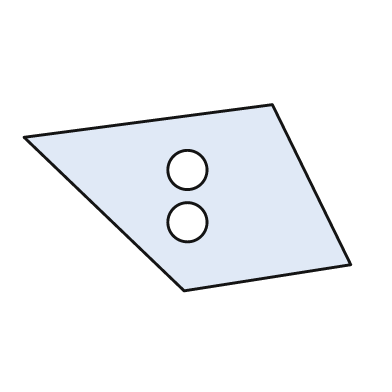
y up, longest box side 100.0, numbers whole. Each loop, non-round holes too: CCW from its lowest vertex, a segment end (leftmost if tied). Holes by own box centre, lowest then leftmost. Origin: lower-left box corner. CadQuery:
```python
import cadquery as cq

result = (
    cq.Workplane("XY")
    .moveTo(49.0, 0.0)
    .lineTo(100.0, 8.0)
    .lineTo(76.0, 57.0)
    .lineTo(0.0, 47.0)
    .close()
    .moveTo(50.0, 21.0)
    .circle(6.0)
    .moveTo(50.0, 37.0)
    .circle(6.0)
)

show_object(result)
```